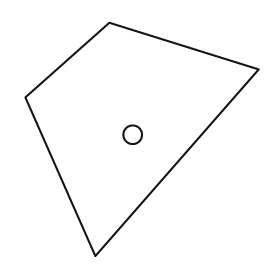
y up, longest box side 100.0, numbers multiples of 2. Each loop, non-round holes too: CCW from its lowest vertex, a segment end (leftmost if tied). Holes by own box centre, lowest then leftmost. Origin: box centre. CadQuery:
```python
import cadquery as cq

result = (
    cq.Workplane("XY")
    .moveTo(-20.0, -50.0)
    .lineTo(50.0, 30.0)
    .lineTo(-14.0, 50.0)
    .lineTo(-50.0, 18.0)
    .close()
    .moveTo(-4.0, 2.0)
    .circle(4.0)
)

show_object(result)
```